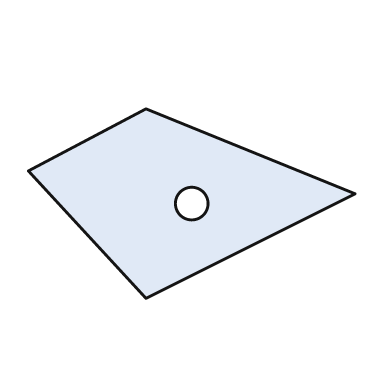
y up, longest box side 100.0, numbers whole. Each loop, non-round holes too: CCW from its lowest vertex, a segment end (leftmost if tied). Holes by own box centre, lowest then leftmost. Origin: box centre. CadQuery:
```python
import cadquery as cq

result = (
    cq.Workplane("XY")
    .moveTo(-14.0, -29.0)
    .lineTo(50.0, 3.0)
    .lineTo(-14.0, 29.0)
    .lineTo(-50.0, 10.0)
    .close()
    .moveTo(0.0, 0.0)
    .circle(5.0)
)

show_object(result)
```